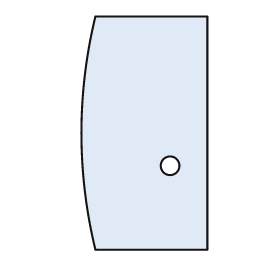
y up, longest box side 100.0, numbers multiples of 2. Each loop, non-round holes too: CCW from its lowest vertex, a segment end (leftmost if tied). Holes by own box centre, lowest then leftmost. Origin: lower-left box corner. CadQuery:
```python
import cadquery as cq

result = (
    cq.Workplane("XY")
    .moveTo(6.0, 0.0)
    .lineTo(54.0, 0.0)
    .lineTo(54.0, 100.0)
    .lineTo(6.0, 100.0)
    .threePointArc((0.0, 50.0), (6.0, 0.0))
    .close()
    .moveTo(38.0, 36.0)
    .circle(4.0)
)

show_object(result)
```